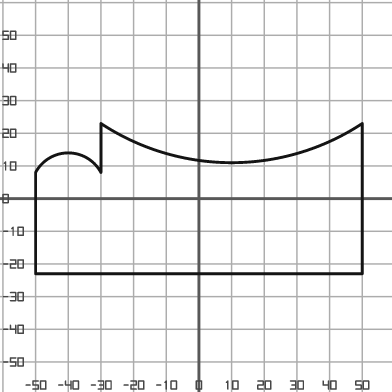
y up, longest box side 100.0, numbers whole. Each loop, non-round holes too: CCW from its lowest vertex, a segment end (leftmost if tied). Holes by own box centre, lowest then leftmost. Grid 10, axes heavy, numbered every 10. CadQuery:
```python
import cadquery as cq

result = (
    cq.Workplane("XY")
    .moveTo(-50.0, -23.0)
    .lineTo(50.0, -23.0)
    .lineTo(50.0, 23.0)
    .threePointArc((10.0, 11.0), (-30.0, 23.0))
    .lineTo(-30.0, 8.0)
    .threePointArc((-40.0, 14.0), (-50.0, 8.0))
    .close()
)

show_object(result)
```